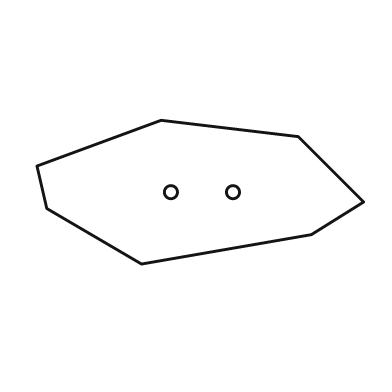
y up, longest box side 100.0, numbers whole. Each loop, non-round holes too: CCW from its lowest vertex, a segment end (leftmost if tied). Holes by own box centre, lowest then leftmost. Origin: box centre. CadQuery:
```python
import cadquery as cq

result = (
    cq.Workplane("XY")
    .moveTo(-18.0, -22.0)
    .lineTo(34.0, -13.0)
    .lineTo(50.0, -3.0)
    .lineTo(30.0, 17.0)
    .lineTo(-12.0, 22.0)
    .lineTo(-50.0, 8.0)
    .lineTo(-47.0, -5.0)
    .close()
    .moveTo(-9.0, 0.0)
    .circle(2.0)
    .moveTo(10.0, 0.0)
    .circle(2.0)
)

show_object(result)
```